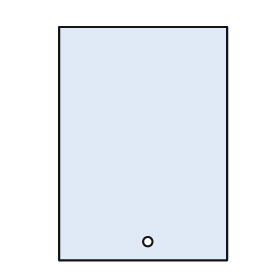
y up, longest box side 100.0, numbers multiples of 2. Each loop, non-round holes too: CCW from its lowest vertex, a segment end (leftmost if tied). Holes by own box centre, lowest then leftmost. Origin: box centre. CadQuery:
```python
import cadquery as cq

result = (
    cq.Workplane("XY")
    .moveTo(-36.0, -50.0)
    .lineTo(36.0, -50.0)
    .lineTo(36.0, 50.0)
    .lineTo(-36.0, 50.0)
    .close()
    .moveTo(2.0, -42.0)
    .circle(2.0)
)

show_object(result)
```